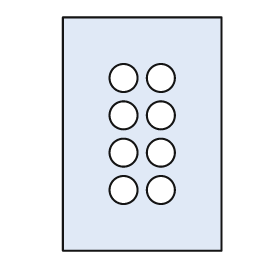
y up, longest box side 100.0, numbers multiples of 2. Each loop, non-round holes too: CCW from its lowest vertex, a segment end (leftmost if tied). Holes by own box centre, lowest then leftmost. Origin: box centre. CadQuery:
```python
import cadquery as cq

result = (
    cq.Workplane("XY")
    .moveTo(-34.0, -50.0)
    .lineTo(34.0, -50.0)
    .lineTo(34.0, 50.0)
    .lineTo(-34.0, 50.0)
    .close()
    .moveTo(-8.0, -24.0)
    .circle(6.0)
    .moveTo(8.0, -24.0)
    .circle(6.0)
    .moveTo(-8.0, -8.0)
    .circle(6.0)
    .moveTo(8.0, -8.0)
    .circle(6.0)
    .moveTo(-8.0, 8.0)
    .circle(6.0)
    .moveTo(8.0, 8.0)
    .circle(6.0)
    .moveTo(-8.0, 24.0)
    .circle(6.0)
    .moveTo(8.0, 24.0)
    .circle(6.0)
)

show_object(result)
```